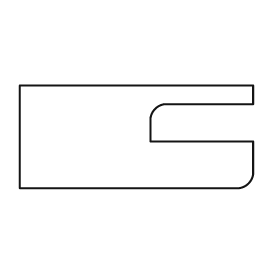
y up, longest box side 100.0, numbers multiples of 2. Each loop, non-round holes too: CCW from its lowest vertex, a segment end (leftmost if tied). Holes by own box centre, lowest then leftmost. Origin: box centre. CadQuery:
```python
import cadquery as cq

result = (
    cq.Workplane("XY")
    .moveTo(-50.0, -22.0)
    .lineTo(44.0, -22.0)
    .threePointArc((48.0, -20.0), (50.0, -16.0))
    .lineTo(50.0, -2.0)
    .lineTo(6.0, -2.0)
    .lineTo(6.0, 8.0)
    .threePointArc((8.0, 12.0), (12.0, 14.0))
    .lineTo(50.0, 14.0)
    .lineTo(50.0, 22.0)
    .lineTo(-50.0, 22.0)
    .close()
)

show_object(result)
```